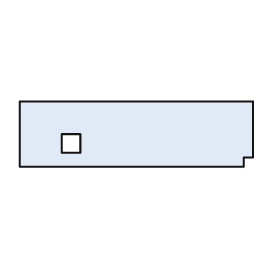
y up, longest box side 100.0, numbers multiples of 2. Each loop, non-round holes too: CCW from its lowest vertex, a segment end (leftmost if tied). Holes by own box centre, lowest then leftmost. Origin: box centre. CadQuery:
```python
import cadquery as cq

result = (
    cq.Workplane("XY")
    .moveTo(-50.0, -14.0)
    .lineTo(46.0, -14.0)
    .lineTo(46.0, -10.0)
    .lineTo(50.0, -10.0)
    .lineTo(50.0, 14.0)
    .lineTo(-50.0, 14.0)
    .close()
    .moveTo(-32.0, -8.0)
    .lineTo(-24.0, -8.0)
    .lineTo(-24.0, 0.0)
    .lineTo(-32.0, 0.0)
    .close()
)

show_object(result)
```